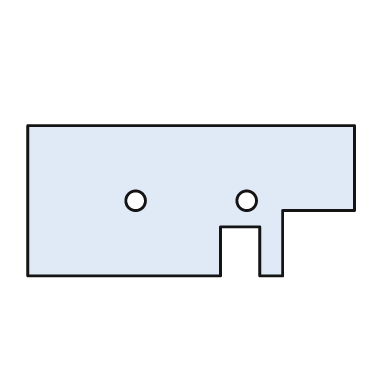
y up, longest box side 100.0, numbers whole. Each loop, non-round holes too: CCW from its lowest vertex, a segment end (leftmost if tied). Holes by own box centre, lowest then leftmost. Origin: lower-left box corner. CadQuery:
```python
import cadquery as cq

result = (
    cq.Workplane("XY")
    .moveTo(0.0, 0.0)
    .lineTo(59.0, 0.0)
    .lineTo(59.0, 15.0)
    .lineTo(71.0, 15.0)
    .lineTo(71.0, 0.0)
    .lineTo(78.0, 0.0)
    .lineTo(78.0, 20.0)
    .lineTo(100.0, 20.0)
    .lineTo(100.0, 46.0)
    .lineTo(0.0, 46.0)
    .close()
    .moveTo(33.0, 23.0)
    .circle(3.0)
    .moveTo(67.0, 23.0)
    .circle(3.0)
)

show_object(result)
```